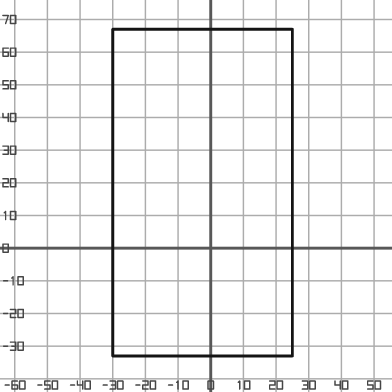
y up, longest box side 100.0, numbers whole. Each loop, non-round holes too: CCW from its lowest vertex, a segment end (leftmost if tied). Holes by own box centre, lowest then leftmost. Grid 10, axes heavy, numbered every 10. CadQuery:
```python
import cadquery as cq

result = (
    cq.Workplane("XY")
    .moveTo(-30.0, -33.0)
    .lineTo(25.0, -33.0)
    .lineTo(25.0, 67.0)
    .lineTo(-30.0, 67.0)
    .close()
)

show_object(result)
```